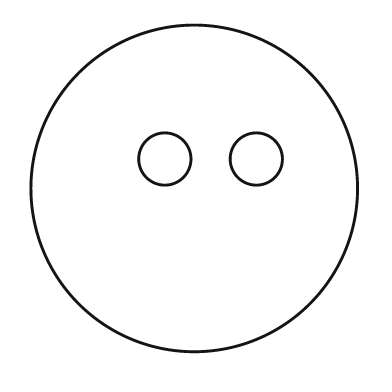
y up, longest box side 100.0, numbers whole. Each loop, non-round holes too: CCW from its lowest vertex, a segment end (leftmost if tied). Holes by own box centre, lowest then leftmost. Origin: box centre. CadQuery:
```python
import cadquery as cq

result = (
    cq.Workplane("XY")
    .moveTo(0.0, 0.0)
    .circle(50.0)
    .moveTo(-9.0, 9.0)
    .circle(8.0)
    .moveTo(19.0, 9.0)
    .circle(8.0)
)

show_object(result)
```